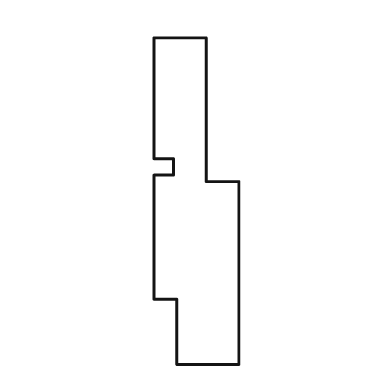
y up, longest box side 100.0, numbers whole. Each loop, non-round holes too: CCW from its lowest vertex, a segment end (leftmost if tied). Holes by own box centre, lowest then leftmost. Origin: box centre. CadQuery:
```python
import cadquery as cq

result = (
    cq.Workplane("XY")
    .moveTo(-6.0, -50.0)
    .lineTo(13.0, -50.0)
    .lineTo(13.0, 6.0)
    .lineTo(3.0, 6.0)
    .lineTo(3.0, 50.0)
    .lineTo(-13.0, 50.0)
    .lineTo(-13.0, 13.0)
    .lineTo(-7.0, 13.0)
    .lineTo(-7.0, 8.0)
    .lineTo(-13.0, 8.0)
    .lineTo(-13.0, -30.0)
    .lineTo(-6.0, -30.0)
    .close()
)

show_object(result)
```